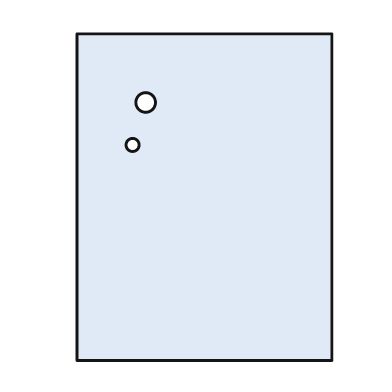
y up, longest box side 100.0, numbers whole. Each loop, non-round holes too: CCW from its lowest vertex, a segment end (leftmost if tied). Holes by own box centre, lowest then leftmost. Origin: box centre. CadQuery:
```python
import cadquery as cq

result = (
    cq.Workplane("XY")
    .moveTo(-39.0, -50.0)
    .lineTo(39.0, -50.0)
    .lineTo(39.0, 50.0)
    .lineTo(-39.0, 50.0)
    .close()
    .moveTo(-22.0, 16.0)
    .circle(2.0)
    .moveTo(-18.0, 29.0)
    .circle(3.0)
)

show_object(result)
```